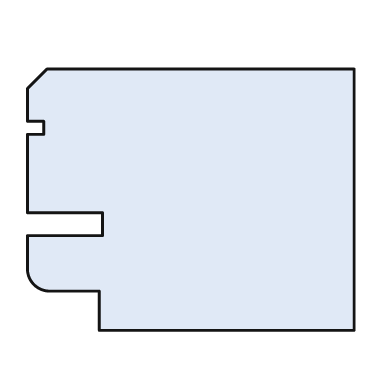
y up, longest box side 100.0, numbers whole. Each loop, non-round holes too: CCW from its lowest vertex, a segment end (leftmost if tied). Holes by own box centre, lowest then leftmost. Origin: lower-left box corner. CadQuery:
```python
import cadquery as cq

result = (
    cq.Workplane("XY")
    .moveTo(22.0, 0.0)
    .lineTo(100.0, 0.0)
    .lineTo(100.0, 80.0)
    .lineTo(6.0, 80.0)
    .lineTo(0.0, 74.0)
    .lineTo(0.0, 64.0)
    .lineTo(5.0, 64.0)
    .lineTo(5.0, 60.0)
    .lineTo(0.0, 60.0)
    .lineTo(0.0, 36.0)
    .lineTo(23.0, 36.0)
    .lineTo(23.0, 29.0)
    .lineTo(0.0, 29.0)
    .lineTo(0.0, 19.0)
    .threePointArc((2.0, 14.0), (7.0, 12.0))
    .lineTo(22.0, 12.0)
    .close()
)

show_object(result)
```